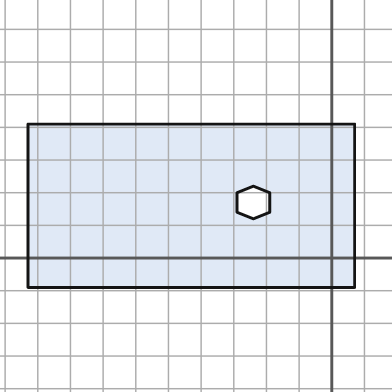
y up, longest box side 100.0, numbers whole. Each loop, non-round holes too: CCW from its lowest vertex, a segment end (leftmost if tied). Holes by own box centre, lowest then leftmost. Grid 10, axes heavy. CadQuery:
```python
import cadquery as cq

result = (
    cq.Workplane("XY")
    .moveTo(-93.0, -9.0)
    .lineTo(7.0, -9.0)
    .lineTo(7.0, 41.0)
    .lineTo(-93.0, 41.0)
    .close()
    .moveTo(-24.0, 12.0)
    .lineTo(-19.0, 14.0)
    .lineTo(-19.0, 20.0)
    .lineTo(-24.0, 22.0)
    .lineTo(-29.0, 20.0)
    .lineTo(-29.0, 14.0)
    .close()
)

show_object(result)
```